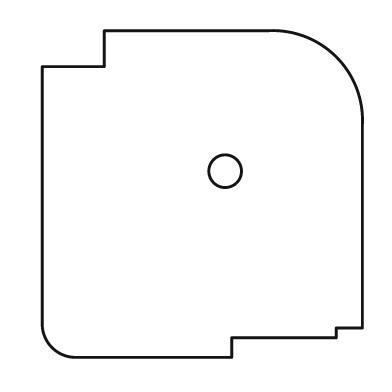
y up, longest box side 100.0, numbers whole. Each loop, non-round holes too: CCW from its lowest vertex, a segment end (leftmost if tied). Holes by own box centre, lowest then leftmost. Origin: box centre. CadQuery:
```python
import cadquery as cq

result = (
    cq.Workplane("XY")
    .moveTo(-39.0, -50.0)
    .lineTo(9.0, -50.0)
    .lineTo(9.0, -44.0)
    .lineTo(41.0, -44.0)
    .lineTo(41.0, -41.0)
    .lineTo(49.0, -41.0)
    .lineTo(49.0, 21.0)
    .threePointArc((41.0, 42.0), (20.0, 50.0))
    .lineTo(-30.0, 50.0)
    .lineTo(-30.0, 39.0)
    .lineTo(-49.0, 39.0)
    .lineTo(-49.0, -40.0)
    .threePointArc((-46.0, -47.0), (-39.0, -50.0))
    .close()
    .moveTo(7.0, 7.0)
    .circle(5.0)
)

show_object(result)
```